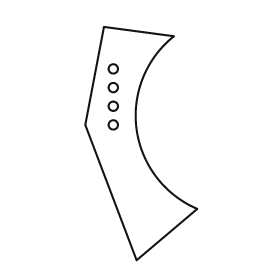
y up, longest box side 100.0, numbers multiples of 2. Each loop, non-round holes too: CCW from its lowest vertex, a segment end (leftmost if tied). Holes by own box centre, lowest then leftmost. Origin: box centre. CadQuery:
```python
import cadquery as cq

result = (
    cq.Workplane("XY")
    .moveTo(-2.0, -50.0)
    .lineTo(24.0, -28.0)
    .threePointArc((-2.0, 6.0), (14.0, 46.0))
    .lineTo(-16.0, 50.0)
    .lineTo(-24.0, 8.0)
    .close()
    .moveTo(-12.0, 8.0)
    .circle(2.0)
    .moveTo(-12.0, 16.0)
    .circle(2.0)
    .moveTo(-12.0, 24.0)
    .circle(2.0)
    .moveTo(-12.0, 32.0)
    .circle(2.0)
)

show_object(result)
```